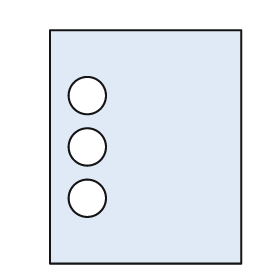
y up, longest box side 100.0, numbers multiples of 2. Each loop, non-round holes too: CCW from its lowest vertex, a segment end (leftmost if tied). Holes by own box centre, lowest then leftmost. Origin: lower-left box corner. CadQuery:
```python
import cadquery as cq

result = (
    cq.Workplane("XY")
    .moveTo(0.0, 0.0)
    .lineTo(82.0, 0.0)
    .lineTo(82.0, 100.0)
    .lineTo(0.0, 100.0)
    .close()
    .moveTo(16.0, 28.0)
    .circle(8.0)
    .moveTo(16.0, 50.0)
    .circle(8.0)
    .moveTo(16.0, 72.0)
    .circle(8.0)
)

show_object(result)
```